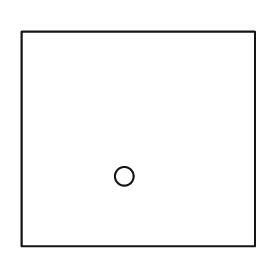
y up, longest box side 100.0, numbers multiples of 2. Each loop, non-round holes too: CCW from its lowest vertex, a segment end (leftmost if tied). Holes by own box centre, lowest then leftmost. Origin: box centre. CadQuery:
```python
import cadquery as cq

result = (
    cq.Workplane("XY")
    .moveTo(-50.0, -46.0)
    .lineTo(50.0, -46.0)
    .lineTo(50.0, 46.0)
    .lineTo(-50.0, 46.0)
    .close()
    .moveTo(-6.0, -16.0)
    .circle(4.0)
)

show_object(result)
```